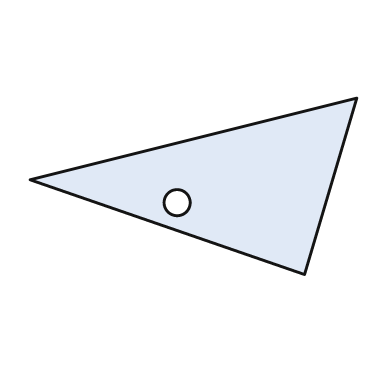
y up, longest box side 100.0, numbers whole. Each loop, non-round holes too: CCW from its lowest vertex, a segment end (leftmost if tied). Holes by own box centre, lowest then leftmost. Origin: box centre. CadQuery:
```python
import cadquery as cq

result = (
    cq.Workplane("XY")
    .moveTo(34.0, -27.0)
    .lineTo(50.0, 27.0)
    .lineTo(-50.0, 2.0)
    .close()
    .moveTo(-5.0, -5.0)
    .circle(4.0)
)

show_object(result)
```